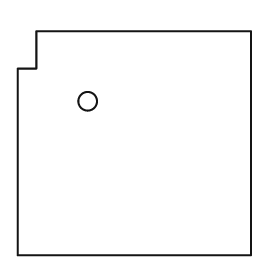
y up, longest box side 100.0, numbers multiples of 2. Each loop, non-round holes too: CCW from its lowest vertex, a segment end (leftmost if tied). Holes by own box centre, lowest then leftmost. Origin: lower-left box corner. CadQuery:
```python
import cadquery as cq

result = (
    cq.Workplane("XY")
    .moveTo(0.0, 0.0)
    .lineTo(100.0, 0.0)
    .lineTo(100.0, 96.0)
    .lineTo(8.0, 96.0)
    .lineTo(8.0, 80.0)
    .lineTo(0.0, 80.0)
    .close()
    .moveTo(30.0, 66.0)
    .circle(4.0)
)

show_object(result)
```